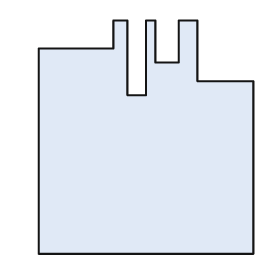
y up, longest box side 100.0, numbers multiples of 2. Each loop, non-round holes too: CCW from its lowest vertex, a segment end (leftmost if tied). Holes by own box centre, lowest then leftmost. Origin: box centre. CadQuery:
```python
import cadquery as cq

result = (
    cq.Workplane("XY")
    .moveTo(-46.0, -50.0)
    .lineTo(46.0, -50.0)
    .lineTo(46.0, 24.0)
    .lineTo(22.0, 24.0)
    .lineTo(22.0, 50.0)
    .lineTo(14.0, 50.0)
    .lineTo(14.0, 32.0)
    .lineTo(4.0, 32.0)
    .lineTo(4.0, 50.0)
    .lineTo(0.0, 50.0)
    .lineTo(0.0, 18.0)
    .lineTo(-8.0, 18.0)
    .lineTo(-8.0, 50.0)
    .lineTo(-14.0, 50.0)
    .lineTo(-14.0, 38.0)
    .lineTo(-46.0, 38.0)
    .close()
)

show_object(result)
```